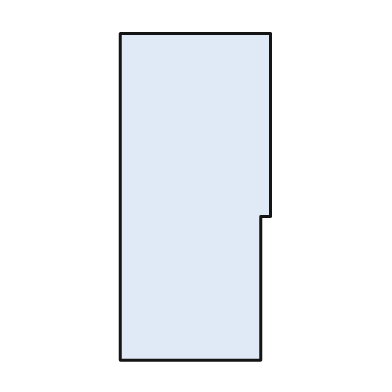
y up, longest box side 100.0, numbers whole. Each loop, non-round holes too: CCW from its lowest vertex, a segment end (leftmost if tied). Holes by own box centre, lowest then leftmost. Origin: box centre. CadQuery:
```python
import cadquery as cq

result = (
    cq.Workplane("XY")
    .moveTo(-23.0, -50.0)
    .lineTo(20.0, -50.0)
    .lineTo(20.0, -6.0)
    .lineTo(23.0, -6.0)
    .lineTo(23.0, 50.0)
    .lineTo(-23.0, 50.0)
    .close()
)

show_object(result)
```